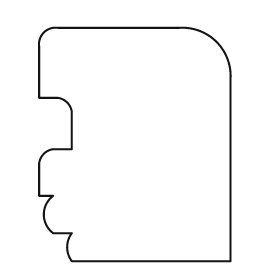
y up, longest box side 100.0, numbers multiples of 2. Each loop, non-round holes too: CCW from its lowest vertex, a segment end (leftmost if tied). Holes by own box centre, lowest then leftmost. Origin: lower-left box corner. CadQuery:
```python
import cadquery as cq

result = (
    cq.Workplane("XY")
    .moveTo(14.0, 0.0)
    .lineTo(82.0, 0.0)
    .lineTo(82.0, 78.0)
    .threePointArc((76.0, 94.0), (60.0, 100.0))
    .lineTo(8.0, 100.0)
    .threePointArc((2.0, 98.0), (0.0, 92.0))
    .lineTo(0.0, 70.0)
    .lineTo(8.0, 70.0)
    .threePointArc((12.0, 68.0), (14.0, 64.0))
    .lineTo(14.0, 48.0)
    .lineTo(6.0, 48.0)
    .threePointArc((2.0, 46.0), (0.0, 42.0))
    .lineTo(0.0, 28.0)
    .lineTo(6.0, 28.0)
    .threePointArc((2.0, 20.0), (6.0, 12.0))
    .lineTo(14.0, 12.0)
    .threePointArc((12.0, 6.0), (14.0, 0.0))
    .close()
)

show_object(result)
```